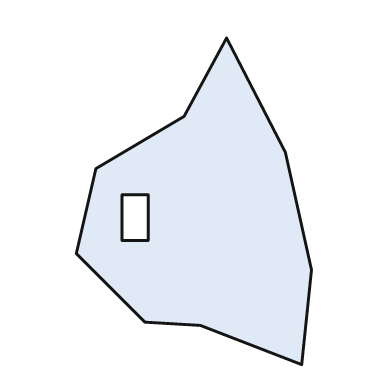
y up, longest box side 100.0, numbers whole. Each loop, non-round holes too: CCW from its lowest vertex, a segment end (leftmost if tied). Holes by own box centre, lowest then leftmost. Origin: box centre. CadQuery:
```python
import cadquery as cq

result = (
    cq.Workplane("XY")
    .moveTo(33.0, -50.0)
    .lineTo(36.0, -21.0)
    .lineTo(28.0, 15.0)
    .lineTo(10.0, 50.0)
    .lineTo(-3.0, 26.0)
    .lineTo(-30.0, 10.0)
    .lineTo(-36.0, -16.0)
    .lineTo(-15.0, -37.0)
    .lineTo(2.0, -38.0)
    .close()
    .moveTo(-22.0, -12.0)
    .lineTo(-14.0, -12.0)
    .lineTo(-14.0, 2.0)
    .lineTo(-22.0, 2.0)
    .close()
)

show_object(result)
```